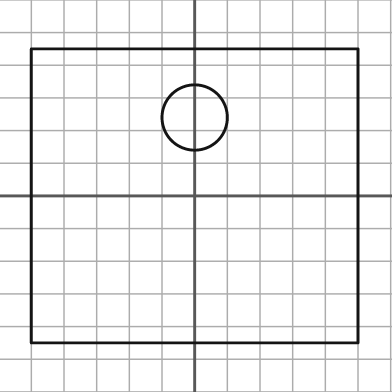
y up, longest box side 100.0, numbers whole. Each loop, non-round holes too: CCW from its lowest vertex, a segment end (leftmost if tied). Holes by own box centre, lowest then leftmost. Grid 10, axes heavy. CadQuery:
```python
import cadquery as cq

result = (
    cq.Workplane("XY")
    .moveTo(-50.0, -45.0)
    .lineTo(50.0, -45.0)
    .lineTo(50.0, 45.0)
    .lineTo(-50.0, 45.0)
    .close()
    .moveTo(0.0, 24.0)
    .circle(10.0)
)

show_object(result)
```